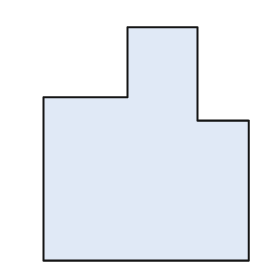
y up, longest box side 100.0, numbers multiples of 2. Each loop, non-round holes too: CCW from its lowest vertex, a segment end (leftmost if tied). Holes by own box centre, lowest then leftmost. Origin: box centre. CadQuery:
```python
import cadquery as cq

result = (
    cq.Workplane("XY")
    .moveTo(-44.0, -50.0)
    .lineTo(44.0, -50.0)
    .lineTo(44.0, 10.0)
    .lineTo(22.0, 10.0)
    .lineTo(22.0, 50.0)
    .lineTo(-8.0, 50.0)
    .lineTo(-8.0, 20.0)
    .lineTo(-44.0, 20.0)
    .close()
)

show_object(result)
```